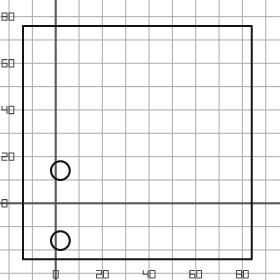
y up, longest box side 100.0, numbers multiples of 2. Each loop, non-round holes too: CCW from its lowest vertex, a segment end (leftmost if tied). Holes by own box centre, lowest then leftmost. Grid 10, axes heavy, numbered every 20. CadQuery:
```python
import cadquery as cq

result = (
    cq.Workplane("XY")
    .moveTo(-14.0, -24.0)
    .lineTo(84.0, -24.0)
    .lineTo(84.0, 76.0)
    .lineTo(-14.0, 76.0)
    .close()
    .moveTo(2.0, -16.0)
    .circle(4.0)
    .moveTo(2.0, 14.0)
    .circle(4.0)
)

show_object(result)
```